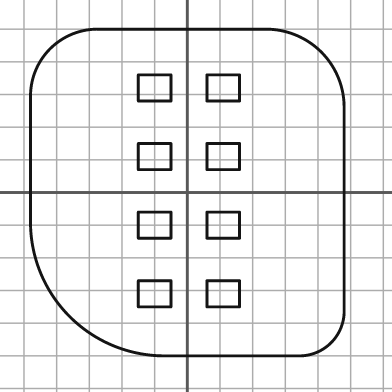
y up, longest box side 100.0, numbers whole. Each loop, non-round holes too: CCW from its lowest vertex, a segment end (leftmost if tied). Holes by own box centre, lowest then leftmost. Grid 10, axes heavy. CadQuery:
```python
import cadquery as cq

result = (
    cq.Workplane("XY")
    .moveTo(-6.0, -50.0)
    .lineTo(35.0, -50.0)
    .threePointArc((44.0, -46.0), (48.0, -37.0))
    .lineTo(48.0, 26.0)
    .threePointArc((41.0, 43.0), (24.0, 50.0))
    .lineTo(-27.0, 50.0)
    .threePointArc((-42.0, 44.0), (-48.0, 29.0))
    .lineTo(-48.0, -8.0)
    .threePointArc((-36.0, -38.0), (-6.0, -50.0))
    .close()
    .moveTo(-15.0, -35.0)
    .lineTo(-5.0, -35.0)
    .lineTo(-5.0, -27.0)
    .lineTo(-15.0, -27.0)
    .close()
    .moveTo(6.0, -35.0)
    .lineTo(16.0, -35.0)
    .lineTo(16.0, -27.0)
    .lineTo(6.0, -27.0)
    .close()
    .moveTo(-15.0, -14.0)
    .lineTo(-5.0, -14.0)
    .lineTo(-5.0, -6.0)
    .lineTo(-15.0, -6.0)
    .close()
    .moveTo(6.0, -14.0)
    .lineTo(16.0, -14.0)
    .lineTo(16.0, -6.0)
    .lineTo(6.0, -6.0)
    .close()
    .moveTo(-15.0, 7.0)
    .lineTo(-5.0, 7.0)
    .lineTo(-5.0, 15.0)
    .lineTo(-15.0, 15.0)
    .close()
    .moveTo(6.0, 7.0)
    .lineTo(16.0, 7.0)
    .lineTo(16.0, 15.0)
    .lineTo(6.0, 15.0)
    .close()
    .moveTo(-15.0, 28.0)
    .lineTo(-5.0, 28.0)
    .lineTo(-5.0, 36.0)
    .lineTo(-15.0, 36.0)
    .close()
    .moveTo(6.0, 28.0)
    .lineTo(16.0, 28.0)
    .lineTo(16.0, 36.0)
    .lineTo(6.0, 36.0)
    .close()
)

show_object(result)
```